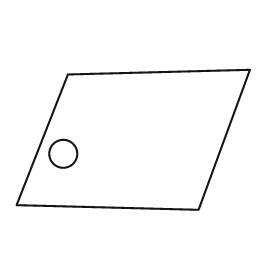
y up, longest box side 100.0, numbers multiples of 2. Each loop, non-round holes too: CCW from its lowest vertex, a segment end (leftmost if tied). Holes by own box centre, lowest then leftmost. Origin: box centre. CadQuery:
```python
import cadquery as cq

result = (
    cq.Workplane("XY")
    .moveTo(28.0, -30.0)
    .lineTo(50.0, 30.0)
    .lineTo(-28.0, 28.0)
    .lineTo(-50.0, -28.0)
    .close()
    .moveTo(-30.0, -6.0)
    .circle(6.0)
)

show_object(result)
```